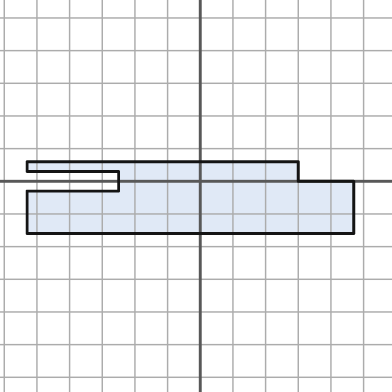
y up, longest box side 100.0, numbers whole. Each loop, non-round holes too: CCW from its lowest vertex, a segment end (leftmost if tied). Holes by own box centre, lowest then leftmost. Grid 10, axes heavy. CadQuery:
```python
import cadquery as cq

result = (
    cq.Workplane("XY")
    .moveTo(-53.0, -16.0)
    .lineTo(47.0, -16.0)
    .lineTo(47.0, 0.0)
    .lineTo(30.0, 0.0)
    .lineTo(30.0, 6.0)
    .lineTo(-53.0, 6.0)
    .lineTo(-53.0, 3.0)
    .lineTo(-25.0, 3.0)
    .lineTo(-25.0, -3.0)
    .lineTo(-53.0, -3.0)
    .close()
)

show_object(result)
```